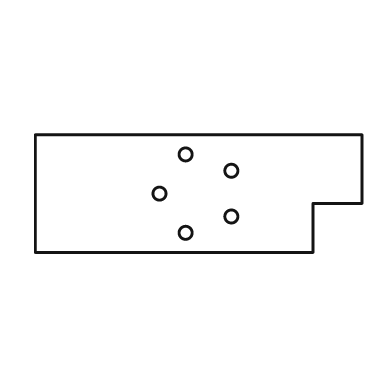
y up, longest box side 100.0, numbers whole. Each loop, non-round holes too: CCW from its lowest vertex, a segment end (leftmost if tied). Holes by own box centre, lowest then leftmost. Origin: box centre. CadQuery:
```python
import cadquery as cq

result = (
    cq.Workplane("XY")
    .moveTo(-50.0, -18.0)
    .lineTo(35.0, -18.0)
    .lineTo(35.0, -3.0)
    .lineTo(50.0, -3.0)
    .lineTo(50.0, 18.0)
    .lineTo(-50.0, 18.0)
    .close()
    .moveTo(-4.0, -12.0)
    .circle(2.0)
    .moveTo(10.0, -7.0)
    .circle(2.0)
    .moveTo(-12.0, 0.0)
    .circle(2.0)
    .moveTo(10.0, 7.0)
    .circle(2.0)
    .moveTo(-4.0, 12.0)
    .circle(2.0)
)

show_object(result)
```